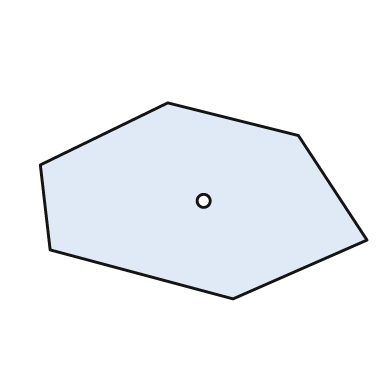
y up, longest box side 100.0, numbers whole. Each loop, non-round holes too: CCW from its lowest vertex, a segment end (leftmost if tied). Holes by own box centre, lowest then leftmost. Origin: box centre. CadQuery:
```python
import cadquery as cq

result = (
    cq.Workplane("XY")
    .moveTo(9.0, -30.0)
    .lineTo(50.0, -12.0)
    .lineTo(29.0, 20.0)
    .lineTo(-11.0, 30.0)
    .lineTo(-50.0, 11.0)
    .lineTo(-47.0, -15.0)
    .close()
    .moveTo(0.0, 0.0)
    .circle(2.0)
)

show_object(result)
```